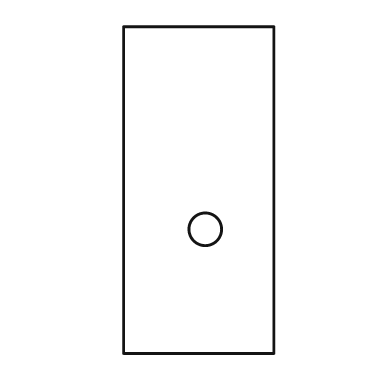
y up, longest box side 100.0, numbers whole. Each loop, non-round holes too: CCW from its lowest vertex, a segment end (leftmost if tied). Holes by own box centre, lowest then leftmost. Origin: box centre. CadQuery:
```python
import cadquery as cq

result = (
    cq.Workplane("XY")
    .moveTo(-23.0, -50.0)
    .lineTo(23.0, -50.0)
    .lineTo(23.0, 50.0)
    .lineTo(-23.0, 50.0)
    .close()
    .moveTo(2.0, -12.0)
    .circle(5.0)
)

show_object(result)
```